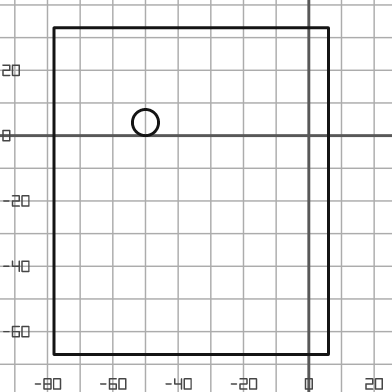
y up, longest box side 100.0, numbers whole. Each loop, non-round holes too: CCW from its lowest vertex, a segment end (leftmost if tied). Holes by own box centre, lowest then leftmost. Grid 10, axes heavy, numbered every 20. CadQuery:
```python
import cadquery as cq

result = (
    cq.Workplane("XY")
    .moveTo(-78.0, -67.0)
    .lineTo(6.0, -67.0)
    .lineTo(6.0, 33.0)
    .lineTo(-78.0, 33.0)
    .close()
    .moveTo(-50.0, 4.0)
    .circle(4.0)
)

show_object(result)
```